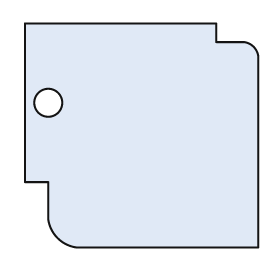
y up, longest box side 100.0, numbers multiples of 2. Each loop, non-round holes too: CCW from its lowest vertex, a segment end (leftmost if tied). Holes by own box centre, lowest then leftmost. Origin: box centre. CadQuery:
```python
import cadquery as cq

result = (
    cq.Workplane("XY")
    .moveTo(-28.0, -48.0)
    .lineTo(50.0, -48.0)
    .lineTo(50.0, 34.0)
    .threePointArc((48.0, 38.0), (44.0, 40.0))
    .lineTo(32.0, 40.0)
    .lineTo(32.0, 48.0)
    .lineTo(-50.0, 48.0)
    .lineTo(-50.0, -20.0)
    .lineTo(-40.0, -20.0)
    .lineTo(-40.0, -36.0)
    .threePointArc((-36.0, -44.0), (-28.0, -48.0))
    .close()
    .moveTo(-40.0, 14.0)
    .circle(6.0)
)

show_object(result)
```